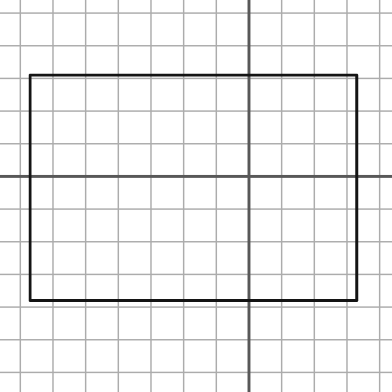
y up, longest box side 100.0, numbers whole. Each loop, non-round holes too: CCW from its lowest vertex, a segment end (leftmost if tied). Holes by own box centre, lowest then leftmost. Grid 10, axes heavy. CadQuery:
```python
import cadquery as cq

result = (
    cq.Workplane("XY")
    .moveTo(-67.0, -38.0)
    .lineTo(33.0, -38.0)
    .lineTo(33.0, 31.0)
    .lineTo(-67.0, 31.0)
    .close()
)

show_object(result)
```